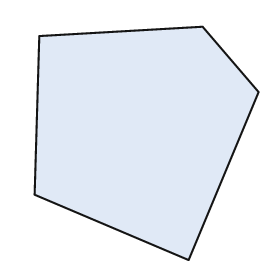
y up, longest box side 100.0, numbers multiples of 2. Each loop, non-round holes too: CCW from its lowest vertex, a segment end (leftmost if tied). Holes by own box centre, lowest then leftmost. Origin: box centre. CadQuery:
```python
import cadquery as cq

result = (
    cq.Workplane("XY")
    .moveTo(18.0, -50.0)
    .lineTo(48.0, 22.0)
    .lineTo(24.0, 50.0)
    .lineTo(-46.0, 46.0)
    .lineTo(-48.0, -22.0)
    .close()
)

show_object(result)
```